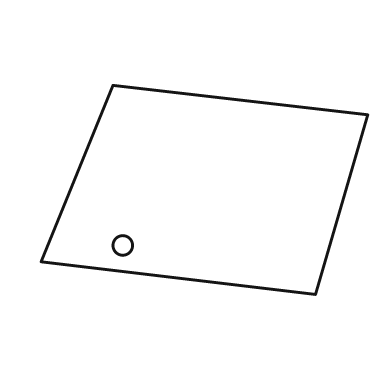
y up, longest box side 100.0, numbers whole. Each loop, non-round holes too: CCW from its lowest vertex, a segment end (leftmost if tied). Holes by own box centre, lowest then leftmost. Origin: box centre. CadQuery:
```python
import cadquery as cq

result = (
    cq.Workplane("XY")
    .moveTo(34.0, -32.0)
    .lineTo(50.0, 23.0)
    .lineTo(-28.0, 32.0)
    .lineTo(-50.0, -22.0)
    .close()
    .moveTo(-25.0, -17.0)
    .circle(3.0)
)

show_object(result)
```